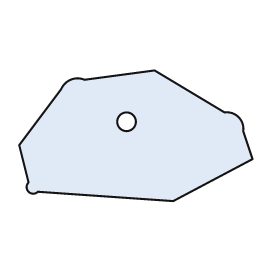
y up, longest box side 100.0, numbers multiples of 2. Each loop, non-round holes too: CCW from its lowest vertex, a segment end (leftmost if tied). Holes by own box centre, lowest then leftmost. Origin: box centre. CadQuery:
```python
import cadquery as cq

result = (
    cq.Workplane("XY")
    .moveTo(16.0, -28.0)
    .lineTo(50.0, -10.0)
    .lineTo(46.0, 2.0)
    .threePointArc((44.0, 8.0), (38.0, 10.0))
    .lineTo(8.0, 28.0)
    .lineTo(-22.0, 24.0)
    .threePointArc((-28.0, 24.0), (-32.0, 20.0))
    .lineTo(-50.0, -4.0)
    .lineTo(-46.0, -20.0)
    .threePointArc((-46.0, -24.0), (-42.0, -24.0))
    .close()
    .moveTo(-4.0, 6.0)
    .circle(4.0)
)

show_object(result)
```